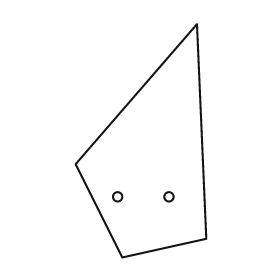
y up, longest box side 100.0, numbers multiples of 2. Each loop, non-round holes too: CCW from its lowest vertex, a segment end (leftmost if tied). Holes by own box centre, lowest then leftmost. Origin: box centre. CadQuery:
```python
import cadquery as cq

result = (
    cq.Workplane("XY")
    .moveTo(-8.0, -50.0)
    .lineTo(28.0, -42.0)
    .lineTo(24.0, 50.0)
    .lineTo(-28.0, -10.0)
    .close()
    .moveTo(-10.0, -24.0)
    .circle(2.0)
    .moveTo(12.0, -24.0)
    .circle(2.0)
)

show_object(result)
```